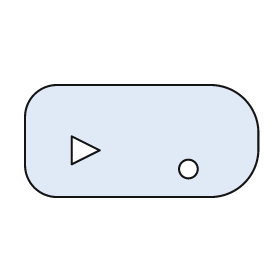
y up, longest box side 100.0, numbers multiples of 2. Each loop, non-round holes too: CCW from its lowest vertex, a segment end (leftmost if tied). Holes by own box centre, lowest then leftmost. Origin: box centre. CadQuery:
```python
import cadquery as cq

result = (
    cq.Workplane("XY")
    .moveTo(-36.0, -24.0)
    .lineTo(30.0, -24.0)
    .threePointArc((44.0, -18.0), (50.0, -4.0))
    .lineTo(50.0, 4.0)
    .threePointArc((44.0, 18.0), (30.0, 24.0))
    .lineTo(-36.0, 24.0)
    .threePointArc((-46.0, 20.0), (-50.0, 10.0))
    .lineTo(-50.0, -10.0)
    .threePointArc((-46.0, -20.0), (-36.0, -24.0))
    .close()
    .moveTo(20.0, -12.0)
    .circle(4.0)
    .moveTo(-30.0, -10.0)
    .lineTo(-18.0, -4.0)
    .lineTo(-30.0, 2.0)
    .close()
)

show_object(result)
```